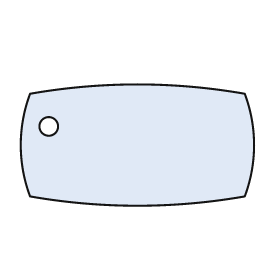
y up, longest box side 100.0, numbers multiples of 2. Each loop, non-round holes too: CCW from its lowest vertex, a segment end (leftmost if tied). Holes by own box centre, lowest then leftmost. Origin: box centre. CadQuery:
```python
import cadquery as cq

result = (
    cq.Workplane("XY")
    .moveTo(-46.0, -22.0)
    .threePointArc((0.0, -26.0), (46.0, -22.0))
    .threePointArc((50.0, 0.0), (46.0, 22.0))
    .threePointArc((0.0, 26.0), (-46.0, 22.0))
    .threePointArc((-50.0, 0.0), (-46.0, -22.0))
    .close()
    .moveTo(-38.0, 8.0)
    .circle(4.0)
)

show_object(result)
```